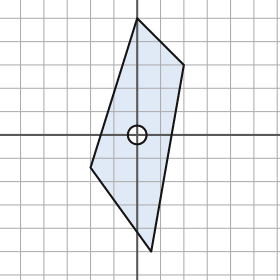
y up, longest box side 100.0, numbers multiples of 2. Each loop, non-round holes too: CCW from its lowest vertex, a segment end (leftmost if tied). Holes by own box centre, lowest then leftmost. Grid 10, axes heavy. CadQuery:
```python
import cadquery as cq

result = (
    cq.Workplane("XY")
    .moveTo(6.0, -50.0)
    .lineTo(20.0, 30.0)
    .lineTo(0.0, 50.0)
    .lineTo(-20.0, -14.0)
    .close()
    .moveTo(0.0, 0.0)
    .circle(4.0)
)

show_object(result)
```